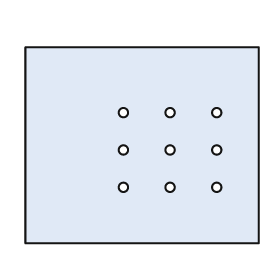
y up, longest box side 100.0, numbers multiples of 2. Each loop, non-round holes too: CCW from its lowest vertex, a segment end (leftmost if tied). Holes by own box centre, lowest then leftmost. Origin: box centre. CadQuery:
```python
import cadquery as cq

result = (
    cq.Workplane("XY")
    .moveTo(-50.0, -42.0)
    .lineTo(50.0, -42.0)
    .lineTo(50.0, 42.0)
    .lineTo(-50.0, 42.0)
    .close()
    .moveTo(-8.0, -18.0)
    .circle(2.0)
    .moveTo(12.0, -18.0)
    .circle(2.0)
    .moveTo(32.0, -18.0)
    .circle(2.0)
    .moveTo(-8.0, -2.0)
    .circle(2.0)
    .moveTo(12.0, -2.0)
    .circle(2.0)
    .moveTo(32.0, -2.0)
    .circle(2.0)
    .moveTo(-8.0, 14.0)
    .circle(2.0)
    .moveTo(12.0, 14.0)
    .circle(2.0)
    .moveTo(32.0, 14.0)
    .circle(2.0)
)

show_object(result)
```